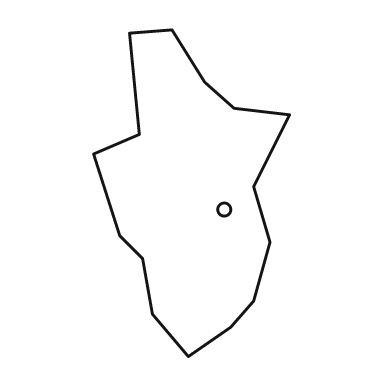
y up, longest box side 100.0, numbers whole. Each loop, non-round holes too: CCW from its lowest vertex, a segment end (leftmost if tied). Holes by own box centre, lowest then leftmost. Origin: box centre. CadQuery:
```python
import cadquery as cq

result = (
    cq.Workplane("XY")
    .moveTo(-1.0, -50.0)
    .lineTo(12.0, -41.0)
    .lineTo(19.0, -33.0)
    .lineTo(24.0, -15.0)
    .lineTo(19.0, 2.0)
    .lineTo(30.0, 24.0)
    .lineTo(13.0, 26.0)
    .lineTo(4.0, 34.0)
    .lineTo(-6.0, 50.0)
    .lineTo(-19.0, 49.0)
    .lineTo(-16.0, 18.0)
    .lineTo(-30.0, 12.0)
    .lineTo(-22.0, -13.0)
    .lineTo(-15.0, -20.0)
    .lineTo(-12.0, -37.0)
    .close()
    .moveTo(10.0, -5.0)
    .circle(2.0)
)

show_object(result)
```